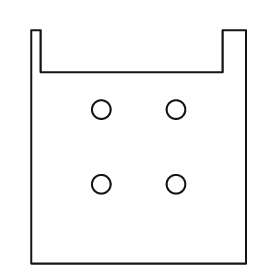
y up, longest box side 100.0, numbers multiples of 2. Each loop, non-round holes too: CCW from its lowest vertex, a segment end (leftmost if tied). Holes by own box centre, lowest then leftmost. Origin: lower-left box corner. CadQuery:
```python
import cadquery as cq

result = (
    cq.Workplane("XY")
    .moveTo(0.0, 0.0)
    .lineTo(92.0, 0.0)
    .lineTo(92.0, 100.0)
    .lineTo(82.0, 100.0)
    .lineTo(82.0, 82.0)
    .lineTo(4.0, 82.0)
    .lineTo(4.0, 100.0)
    .lineTo(0.0, 100.0)
    .close()
    .moveTo(30.0, 34.0)
    .circle(4.0)
    .moveTo(62.0, 34.0)
    .circle(4.0)
    .moveTo(30.0, 66.0)
    .circle(4.0)
    .moveTo(62.0, 66.0)
    .circle(4.0)
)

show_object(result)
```